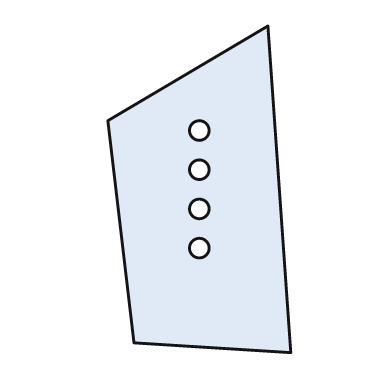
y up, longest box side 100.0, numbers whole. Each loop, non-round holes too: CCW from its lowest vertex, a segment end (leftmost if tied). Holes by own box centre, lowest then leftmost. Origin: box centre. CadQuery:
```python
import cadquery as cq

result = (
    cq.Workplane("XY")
    .moveTo(28.0, -50.0)
    .lineTo(21.0, 50.0)
    .lineTo(-28.0, 21.0)
    .lineTo(-20.0, -47.0)
    .close()
    .moveTo(0.0, -18.0)
    .circle(3.0)
    .moveTo(0.0, -6.0)
    .circle(3.0)
    .moveTo(0.0, 6.0)
    .circle(3.0)
    .moveTo(0.0, 18.0)
    .circle(3.0)
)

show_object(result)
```